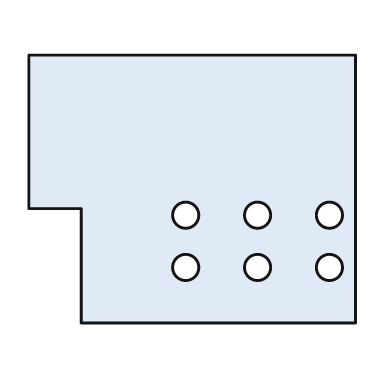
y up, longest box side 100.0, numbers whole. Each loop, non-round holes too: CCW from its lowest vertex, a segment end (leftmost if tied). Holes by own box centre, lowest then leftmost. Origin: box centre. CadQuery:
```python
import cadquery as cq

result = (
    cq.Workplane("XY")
    .moveTo(-34.0, -41.0)
    .lineTo(50.0, -41.0)
    .lineTo(50.0, 41.0)
    .lineTo(-50.0, 41.0)
    .lineTo(-50.0, -6.0)
    .lineTo(-34.0, -6.0)
    .close()
    .moveTo(-2.0, -24.0)
    .circle(4.0)
    .moveTo(20.0, -24.0)
    .circle(4.0)
    .moveTo(42.0, -24.0)
    .circle(4.0)
    .moveTo(-2.0, -8.0)
    .circle(4.0)
    .moveTo(20.0, -8.0)
    .circle(4.0)
    .moveTo(42.0, -8.0)
    .circle(4.0)
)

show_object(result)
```